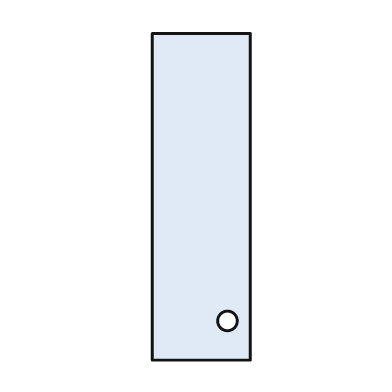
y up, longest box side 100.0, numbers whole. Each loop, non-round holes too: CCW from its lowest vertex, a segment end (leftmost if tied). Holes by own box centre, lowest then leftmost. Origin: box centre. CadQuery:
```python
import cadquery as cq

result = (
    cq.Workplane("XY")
    .moveTo(-15.0, -50.0)
    .lineTo(15.0, -50.0)
    .lineTo(15.0, 50.0)
    .lineTo(-15.0, 50.0)
    .close()
    .moveTo(8.0, -38.0)
    .circle(3.0)
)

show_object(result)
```